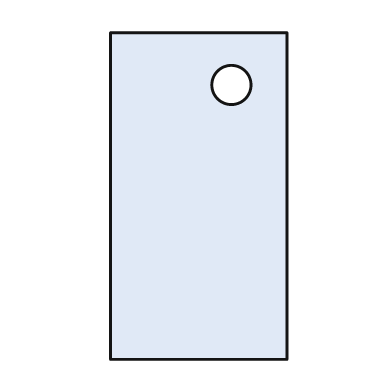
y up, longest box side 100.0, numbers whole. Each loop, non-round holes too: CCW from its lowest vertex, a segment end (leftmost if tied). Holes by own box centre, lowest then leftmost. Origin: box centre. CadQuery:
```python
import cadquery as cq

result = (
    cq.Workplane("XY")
    .moveTo(-27.0, -50.0)
    .lineTo(27.0, -50.0)
    .lineTo(27.0, 50.0)
    .lineTo(-27.0, 50.0)
    .close()
    .moveTo(10.0, 34.0)
    .circle(6.0)
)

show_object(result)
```